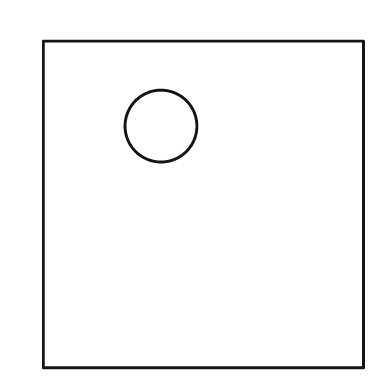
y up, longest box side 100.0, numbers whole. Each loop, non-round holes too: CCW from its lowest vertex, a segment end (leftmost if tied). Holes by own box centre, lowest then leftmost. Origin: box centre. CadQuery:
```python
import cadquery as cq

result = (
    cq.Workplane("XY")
    .moveTo(-49.0, -50.0)
    .lineTo(49.0, -50.0)
    .lineTo(49.0, 50.0)
    .lineTo(-49.0, 50.0)
    .close()
    .moveTo(-13.0, 24.0)
    .circle(11.0)
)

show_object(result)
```